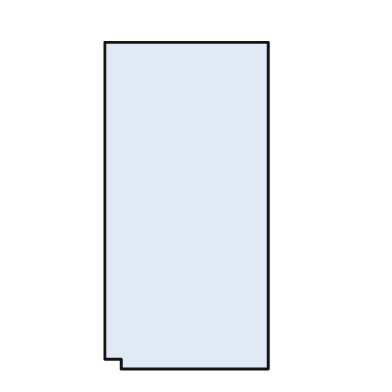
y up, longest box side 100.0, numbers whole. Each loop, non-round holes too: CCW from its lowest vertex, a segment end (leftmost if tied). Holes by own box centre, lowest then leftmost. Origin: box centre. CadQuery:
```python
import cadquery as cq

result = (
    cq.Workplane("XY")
    .moveTo(-20.0, -50.0)
    .lineTo(25.0, -50.0)
    .lineTo(25.0, 50.0)
    .lineTo(-25.0, 50.0)
    .lineTo(-25.0, -47.0)
    .lineTo(-20.0, -47.0)
    .close()
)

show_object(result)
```